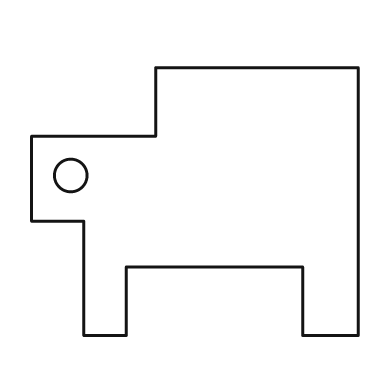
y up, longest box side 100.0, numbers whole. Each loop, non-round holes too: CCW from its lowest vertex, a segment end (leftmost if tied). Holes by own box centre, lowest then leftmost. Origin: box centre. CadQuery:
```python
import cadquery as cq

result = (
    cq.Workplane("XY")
    .moveTo(-34.0, -41.0)
    .lineTo(-21.0, -41.0)
    .lineTo(-21.0, -20.0)
    .lineTo(33.0, -20.0)
    .lineTo(33.0, -41.0)
    .lineTo(50.0, -41.0)
    .lineTo(50.0, 41.0)
    .lineTo(-12.0, 41.0)
    .lineTo(-12.0, 20.0)
    .lineTo(-50.0, 20.0)
    .lineTo(-50.0, -6.0)
    .lineTo(-34.0, -6.0)
    .close()
    .moveTo(-38.0, 8.0)
    .circle(5.0)
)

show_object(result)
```